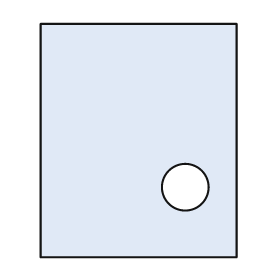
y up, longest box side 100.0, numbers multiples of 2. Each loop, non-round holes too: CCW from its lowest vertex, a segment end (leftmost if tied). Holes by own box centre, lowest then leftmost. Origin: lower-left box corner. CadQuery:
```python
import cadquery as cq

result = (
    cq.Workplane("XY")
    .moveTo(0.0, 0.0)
    .lineTo(84.0, 0.0)
    .lineTo(84.0, 100.0)
    .lineTo(0.0, 100.0)
    .close()
    .moveTo(62.0, 30.0)
    .circle(10.0)
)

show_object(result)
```